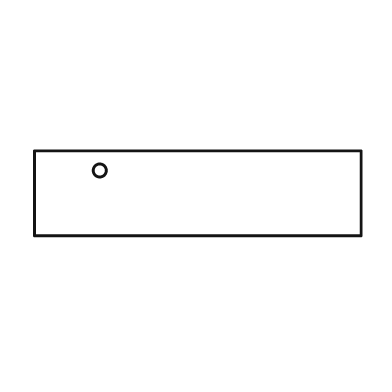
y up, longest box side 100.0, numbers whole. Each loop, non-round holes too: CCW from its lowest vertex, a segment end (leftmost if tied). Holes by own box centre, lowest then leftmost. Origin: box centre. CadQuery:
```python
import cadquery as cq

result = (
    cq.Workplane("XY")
    .moveTo(-50.0, -13.0)
    .lineTo(50.0, -13.0)
    .lineTo(50.0, 13.0)
    .lineTo(-50.0, 13.0)
    .close()
    .moveTo(-30.0, 7.0)
    .circle(2.0)
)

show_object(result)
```